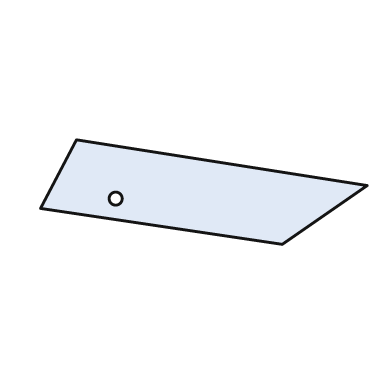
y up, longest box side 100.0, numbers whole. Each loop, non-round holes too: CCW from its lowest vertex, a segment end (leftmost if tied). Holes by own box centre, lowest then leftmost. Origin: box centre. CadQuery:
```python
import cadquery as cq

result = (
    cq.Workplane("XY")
    .moveTo(24.0, -16.0)
    .lineTo(50.0, 2.0)
    .lineTo(-39.0, 16.0)
    .lineTo(-50.0, -5.0)
    .close()
    .moveTo(-27.0, -2.0)
    .circle(2.0)
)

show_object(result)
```